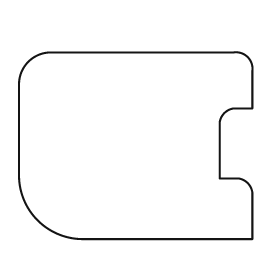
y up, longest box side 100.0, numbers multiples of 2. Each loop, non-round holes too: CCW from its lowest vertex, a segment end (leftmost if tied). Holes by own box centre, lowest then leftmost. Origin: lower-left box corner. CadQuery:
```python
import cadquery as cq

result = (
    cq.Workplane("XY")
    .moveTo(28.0, 0.0)
    .lineTo(100.0, 0.0)
    .lineTo(100.0, 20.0)
    .threePointArc((98.0, 24.0), (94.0, 26.0))
    .lineTo(86.0, 26.0)
    .lineTo(86.0, 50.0)
    .threePointArc((88.0, 54.0), (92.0, 56.0))
    .lineTo(100.0, 56.0)
    .lineTo(100.0, 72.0)
    .threePointArc((98.0, 78.0), (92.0, 80.0))
    .lineTo(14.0, 80.0)
    .threePointArc((4.0, 76.0), (0.0, 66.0))
    .lineTo(0.0, 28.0)
    .threePointArc((8.0, 8.0), (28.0, 0.0))
    .close()
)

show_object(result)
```